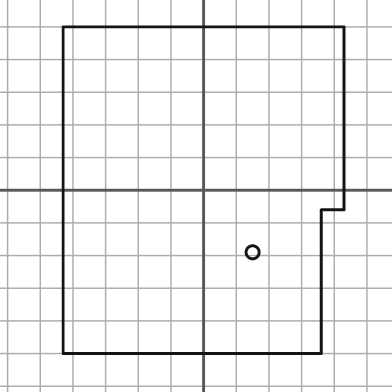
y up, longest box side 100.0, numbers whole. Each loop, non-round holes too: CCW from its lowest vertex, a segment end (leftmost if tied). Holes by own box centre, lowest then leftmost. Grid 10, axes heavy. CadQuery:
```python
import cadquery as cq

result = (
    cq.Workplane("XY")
    .moveTo(-43.0, -50.0)
    .lineTo(36.0, -50.0)
    .lineTo(36.0, -6.0)
    .lineTo(43.0, -6.0)
    .lineTo(43.0, 50.0)
    .lineTo(-43.0, 50.0)
    .close()
    .moveTo(15.0, -19.0)
    .circle(2.0)
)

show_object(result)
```